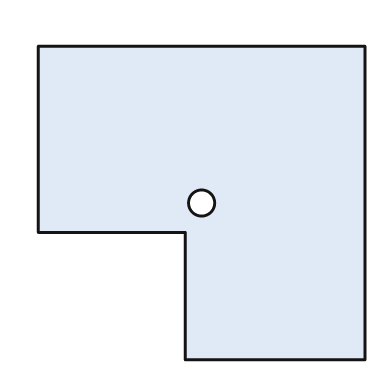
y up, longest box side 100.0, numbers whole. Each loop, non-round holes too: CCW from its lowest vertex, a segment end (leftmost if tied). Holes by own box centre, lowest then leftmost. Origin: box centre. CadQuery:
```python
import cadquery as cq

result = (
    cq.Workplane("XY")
    .moveTo(-5.0, -48.0)
    .lineTo(50.0, -48.0)
    .lineTo(50.0, 48.0)
    .lineTo(-50.0, 48.0)
    .lineTo(-50.0, -9.0)
    .lineTo(-5.0, -9.0)
    .close()
    .moveTo(0.0, 0.0)
    .circle(4.0)
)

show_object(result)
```